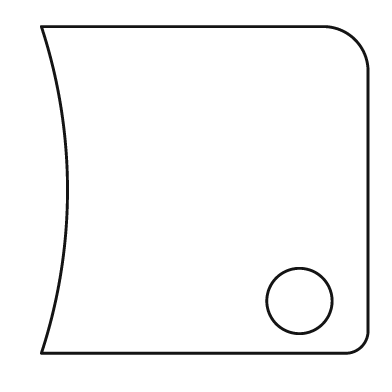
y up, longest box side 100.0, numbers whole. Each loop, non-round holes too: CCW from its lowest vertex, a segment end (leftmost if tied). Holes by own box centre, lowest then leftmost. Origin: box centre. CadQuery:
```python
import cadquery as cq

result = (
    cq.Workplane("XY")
    .moveTo(-50.0, -50.0)
    .lineTo(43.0, -50.0)
    .threePointArc((48.0, -48.0), (50.0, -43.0))
    .lineTo(50.0, 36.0)
    .threePointArc((46.0, 46.0), (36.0, 50.0))
    .lineTo(-50.0, 50.0)
    .threePointArc((-42.0, 0.0), (-50.0, -50.0))
    .close()
    .moveTo(29.0, -34.0)
    .circle(10.0)
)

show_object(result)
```